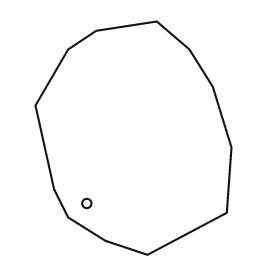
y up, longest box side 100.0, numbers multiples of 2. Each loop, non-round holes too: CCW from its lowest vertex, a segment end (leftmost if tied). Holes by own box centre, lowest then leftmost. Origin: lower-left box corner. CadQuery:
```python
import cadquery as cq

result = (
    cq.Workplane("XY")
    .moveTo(48.0, 0.0)
    .lineTo(82.0, 18.0)
    .lineTo(84.0, 46.0)
    .lineTo(76.0, 72.0)
    .lineTo(66.0, 88.0)
    .lineTo(52.0, 100.0)
    .lineTo(26.0, 96.0)
    .lineTo(14.0, 88.0)
    .lineTo(0.0, 64.0)
    .lineTo(8.0, 28.0)
    .lineTo(14.0, 16.0)
    .lineTo(30.0, 6.0)
    .close()
    .moveTo(22.0, 22.0)
    .circle(2.0)
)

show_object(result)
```